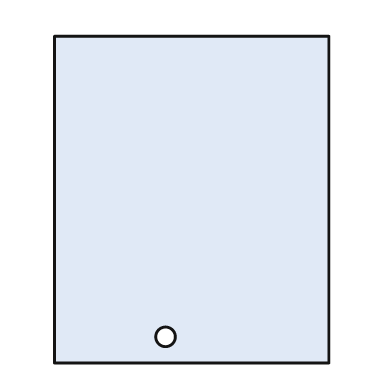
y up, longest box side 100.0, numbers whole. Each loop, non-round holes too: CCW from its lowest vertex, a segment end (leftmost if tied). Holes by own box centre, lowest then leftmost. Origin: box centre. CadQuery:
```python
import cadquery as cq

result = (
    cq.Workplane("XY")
    .moveTo(-42.0, -50.0)
    .lineTo(42.0, -50.0)
    .lineTo(42.0, 50.0)
    .lineTo(-42.0, 50.0)
    .close()
    .moveTo(-8.0, -42.0)
    .circle(3.0)
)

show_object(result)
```